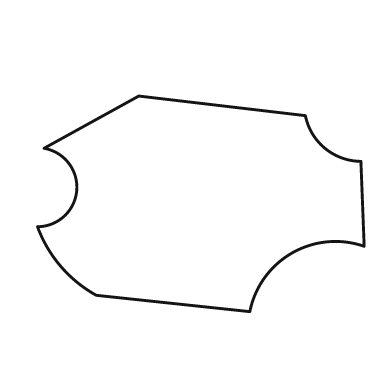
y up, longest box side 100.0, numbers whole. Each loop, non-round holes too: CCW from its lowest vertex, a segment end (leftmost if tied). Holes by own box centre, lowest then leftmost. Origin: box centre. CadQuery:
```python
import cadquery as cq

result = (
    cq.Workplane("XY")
    .moveTo(15.0, -33.0)
    .threePointArc((28.0, -15.0), (50.0, -13.0))
    .lineTo(49.0, 13.0)
    .threePointArc((38.0, 17.0), (32.0, 27.0))
    .lineTo(-19.0, 33.0)
    .lineTo(-48.0, 17.0)
    .threePointArc((-38.0, 4.0), (-50.0, -7.0))
    .threePointArc((-43.0, -19.0), (-32.0, -28.0))
    .close()
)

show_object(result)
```